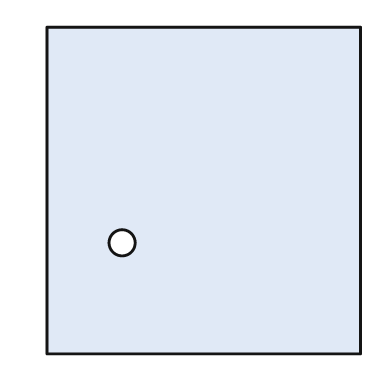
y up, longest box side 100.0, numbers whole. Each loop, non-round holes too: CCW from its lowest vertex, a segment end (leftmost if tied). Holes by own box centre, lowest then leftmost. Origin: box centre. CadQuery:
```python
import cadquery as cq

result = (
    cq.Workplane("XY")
    .moveTo(-48.0, -50.0)
    .lineTo(48.0, -50.0)
    .lineTo(48.0, 50.0)
    .lineTo(-48.0, 50.0)
    .close()
    .moveTo(-25.0, -16.0)
    .circle(4.0)
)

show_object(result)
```